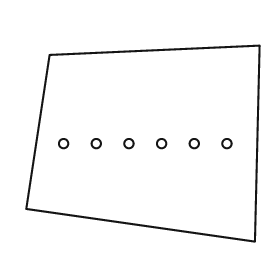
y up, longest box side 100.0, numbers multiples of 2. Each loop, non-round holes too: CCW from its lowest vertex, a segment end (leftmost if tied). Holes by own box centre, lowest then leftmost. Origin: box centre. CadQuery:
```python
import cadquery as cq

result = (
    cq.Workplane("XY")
    .moveTo(48.0, -42.0)
    .lineTo(50.0, 42.0)
    .lineTo(-40.0, 38.0)
    .lineTo(-50.0, -28.0)
    .close()
    .moveTo(-34.0, 0.0)
    .circle(2.0)
    .moveTo(-20.0, 0.0)
    .circle(2.0)
    .moveTo(-6.0, 0.0)
    .circle(2.0)
    .moveTo(8.0, 0.0)
    .circle(2.0)
    .moveTo(22.0, 0.0)
    .circle(2.0)
    .moveTo(36.0, 0.0)
    .circle(2.0)
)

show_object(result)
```